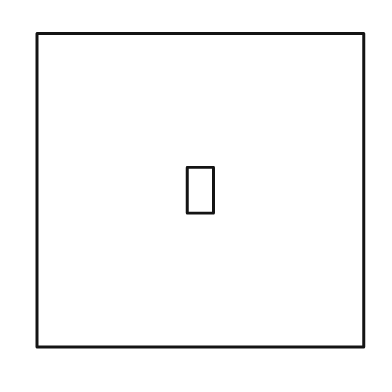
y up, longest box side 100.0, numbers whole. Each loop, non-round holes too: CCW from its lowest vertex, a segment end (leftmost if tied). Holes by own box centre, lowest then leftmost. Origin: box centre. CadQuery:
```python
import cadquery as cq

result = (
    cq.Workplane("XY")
    .moveTo(-50.0, -48.0)
    .lineTo(50.0, -48.0)
    .lineTo(50.0, 48.0)
    .lineTo(-50.0, 48.0)
    .close()
    .moveTo(-4.0, -7.0)
    .lineTo(4.0, -7.0)
    .lineTo(4.0, 7.0)
    .lineTo(-4.0, 7.0)
    .close()
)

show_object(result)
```